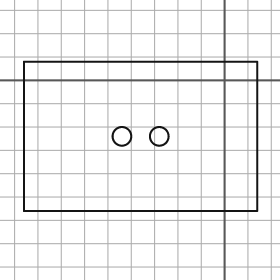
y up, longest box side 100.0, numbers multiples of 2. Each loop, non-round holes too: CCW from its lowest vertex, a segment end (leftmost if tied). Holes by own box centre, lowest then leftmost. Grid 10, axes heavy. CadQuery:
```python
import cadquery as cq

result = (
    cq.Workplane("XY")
    .moveTo(-86.0, -56.0)
    .lineTo(14.0, -56.0)
    .lineTo(14.0, 8.0)
    .lineTo(-86.0, 8.0)
    .close()
    .moveTo(-44.0, -24.0)
    .circle(4.0)
    .moveTo(-28.0, -24.0)
    .circle(4.0)
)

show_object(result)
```